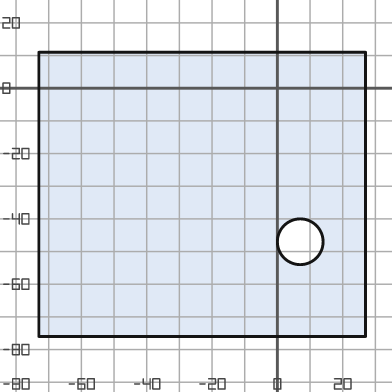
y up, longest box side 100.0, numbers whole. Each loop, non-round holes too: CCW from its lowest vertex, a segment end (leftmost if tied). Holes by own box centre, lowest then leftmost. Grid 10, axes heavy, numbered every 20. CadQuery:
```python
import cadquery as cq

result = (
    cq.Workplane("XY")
    .moveTo(-73.0, -76.0)
    .lineTo(27.0, -76.0)
    .lineTo(27.0, 11.0)
    .lineTo(-73.0, 11.0)
    .close()
    .moveTo(7.0, -47.0)
    .circle(7.0)
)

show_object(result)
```